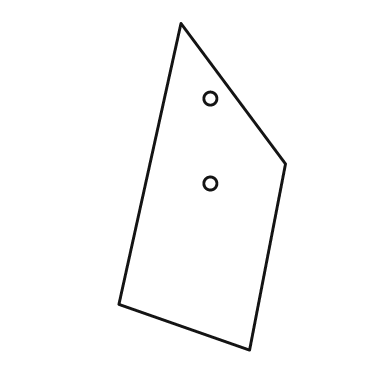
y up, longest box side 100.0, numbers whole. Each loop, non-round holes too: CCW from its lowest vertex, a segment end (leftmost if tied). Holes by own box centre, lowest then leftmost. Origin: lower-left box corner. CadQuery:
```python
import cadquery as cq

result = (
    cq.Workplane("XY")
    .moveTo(40.0, 0.0)
    .lineTo(51.0, 57.0)
    .lineTo(19.0, 100.0)
    .lineTo(0.0, 14.0)
    .close()
    .moveTo(28.0, 51.0)
    .circle(2.0)
    .moveTo(28.0, 77.0)
    .circle(2.0)
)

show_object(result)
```